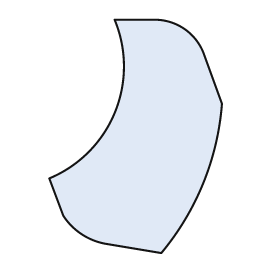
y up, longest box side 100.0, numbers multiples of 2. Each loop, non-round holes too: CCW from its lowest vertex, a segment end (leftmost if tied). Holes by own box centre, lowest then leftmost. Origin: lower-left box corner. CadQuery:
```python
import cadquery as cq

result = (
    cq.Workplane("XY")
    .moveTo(48.0, 0.0)
    .threePointArc((66.0, 30.0), (74.0, 64.0))
    .lineTo(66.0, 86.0)
    .threePointArc((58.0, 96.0), (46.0, 100.0))
    .lineTo(28.0, 100.0)
    .threePointArc((28.0, 60.0), (0.0, 32.0))
    .lineTo(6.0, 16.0)
    .threePointArc((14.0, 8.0), (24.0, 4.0))
    .close()
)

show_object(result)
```